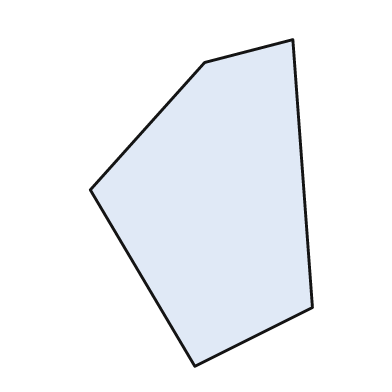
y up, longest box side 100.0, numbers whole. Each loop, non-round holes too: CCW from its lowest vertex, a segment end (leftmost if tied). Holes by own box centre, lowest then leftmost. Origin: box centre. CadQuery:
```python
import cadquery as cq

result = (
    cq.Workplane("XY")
    .moveTo(-2.0, -50.0)
    .lineTo(34.0, -32.0)
    .lineTo(28.0, 50.0)
    .lineTo(1.0, 43.0)
    .lineTo(-34.0, 4.0)
    .close()
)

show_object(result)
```